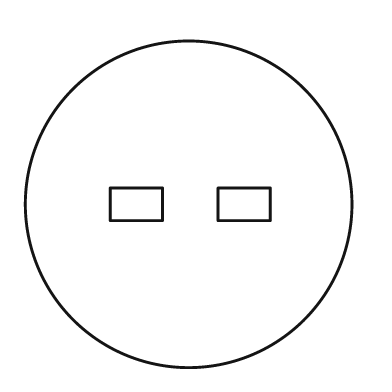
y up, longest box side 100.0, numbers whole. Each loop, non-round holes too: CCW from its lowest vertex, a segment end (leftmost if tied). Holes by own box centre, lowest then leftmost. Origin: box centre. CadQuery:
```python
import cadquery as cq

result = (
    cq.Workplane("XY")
    .moveTo(0.0, 0.0)
    .circle(50.0)
    .moveTo(-24.0, -5.0)
    .lineTo(-8.0, -5.0)
    .lineTo(-8.0, 5.0)
    .lineTo(-24.0, 5.0)
    .close()
    .moveTo(9.0, -5.0)
    .lineTo(25.0, -5.0)
    .lineTo(25.0, 5.0)
    .lineTo(9.0, 5.0)
    .close()
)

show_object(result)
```